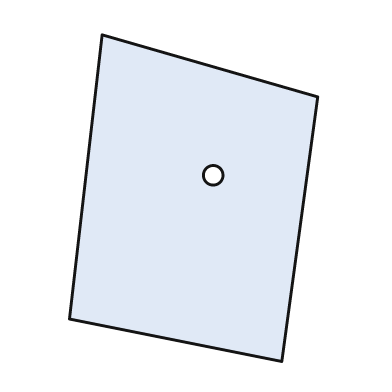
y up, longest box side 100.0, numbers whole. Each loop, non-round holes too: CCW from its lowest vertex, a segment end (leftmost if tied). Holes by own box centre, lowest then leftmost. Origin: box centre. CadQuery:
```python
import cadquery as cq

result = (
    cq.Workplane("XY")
    .moveTo(27.0, -50.0)
    .lineTo(38.0, 31.0)
    .lineTo(-28.0, 50.0)
    .lineTo(-38.0, -37.0)
    .close()
    .moveTo(6.0, 7.0)
    .circle(3.0)
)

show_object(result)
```